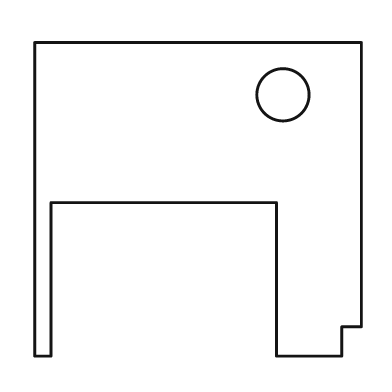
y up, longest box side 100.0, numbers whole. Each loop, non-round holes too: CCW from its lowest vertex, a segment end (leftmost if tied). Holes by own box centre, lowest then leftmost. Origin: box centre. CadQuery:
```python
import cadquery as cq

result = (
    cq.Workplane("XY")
    .moveTo(-50.0, -48.0)
    .lineTo(-45.0, -48.0)
    .lineTo(-45.0, -1.0)
    .lineTo(24.0, -1.0)
    .lineTo(24.0, -48.0)
    .lineTo(44.0, -48.0)
    .lineTo(44.0, -39.0)
    .lineTo(50.0, -39.0)
    .lineTo(50.0, 48.0)
    .lineTo(-50.0, 48.0)
    .close()
    .moveTo(26.0, 32.0)
    .circle(8.0)
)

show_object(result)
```